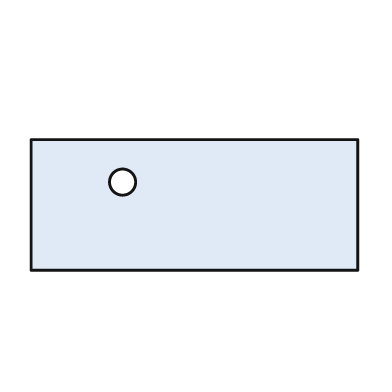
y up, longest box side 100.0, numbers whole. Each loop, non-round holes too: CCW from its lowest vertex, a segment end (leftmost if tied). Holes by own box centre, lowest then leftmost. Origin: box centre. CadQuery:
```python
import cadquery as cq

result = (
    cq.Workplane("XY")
    .moveTo(-50.0, -20.0)
    .lineTo(50.0, -20.0)
    .lineTo(50.0, 20.0)
    .lineTo(-50.0, 20.0)
    .close()
    .moveTo(-22.0, 7.0)
    .circle(4.0)
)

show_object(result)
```